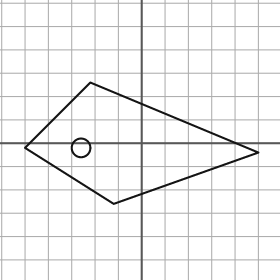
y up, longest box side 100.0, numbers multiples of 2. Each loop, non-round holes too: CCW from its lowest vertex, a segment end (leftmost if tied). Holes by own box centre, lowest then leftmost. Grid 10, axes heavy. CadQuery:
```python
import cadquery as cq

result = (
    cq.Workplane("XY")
    .moveTo(-12.0, -26.0)
    .lineTo(50.0, -4.0)
    .lineTo(-22.0, 26.0)
    .lineTo(-50.0, -2.0)
    .close()
    .moveTo(-26.0, -2.0)
    .circle(4.0)
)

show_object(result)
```